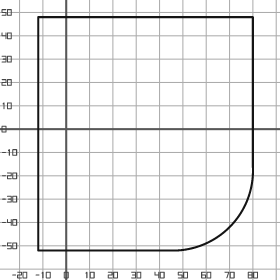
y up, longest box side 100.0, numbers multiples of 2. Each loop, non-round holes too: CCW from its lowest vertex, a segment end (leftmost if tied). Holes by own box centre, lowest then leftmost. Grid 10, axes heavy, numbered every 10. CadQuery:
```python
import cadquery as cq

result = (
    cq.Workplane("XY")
    .moveTo(-12.0, -52.0)
    .lineTo(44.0, -52.0)
    .threePointArc((70.0, -42.0), (80.0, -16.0))
    .lineTo(80.0, 48.0)
    .lineTo(-12.0, 48.0)
    .close()
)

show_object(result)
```